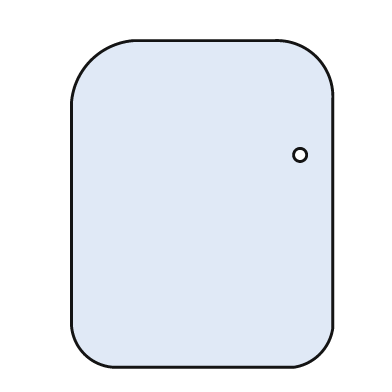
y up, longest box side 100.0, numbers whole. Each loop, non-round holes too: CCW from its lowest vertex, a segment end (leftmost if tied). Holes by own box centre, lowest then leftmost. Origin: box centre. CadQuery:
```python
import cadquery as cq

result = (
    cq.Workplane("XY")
    .moveTo(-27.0, -50.0)
    .lineTo(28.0, -50.0)
    .threePointArc((36.0, -46.0), (40.0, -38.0))
    .lineTo(40.0, 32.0)
    .threePointArc((35.0, 45.0), (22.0, 50.0))
    .lineTo(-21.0, 50.0)
    .threePointArc((-34.0, 44.0), (-40.0, 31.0))
    .lineTo(-40.0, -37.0)
    .threePointArc((-36.0, -46.0), (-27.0, -50.0))
    .close()
    .moveTo(30.0, 15.0)
    .circle(2.0)
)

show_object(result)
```